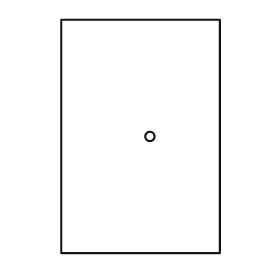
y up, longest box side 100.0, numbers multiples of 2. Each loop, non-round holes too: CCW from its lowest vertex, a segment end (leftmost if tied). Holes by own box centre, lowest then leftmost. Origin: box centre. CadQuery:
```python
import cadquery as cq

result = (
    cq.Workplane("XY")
    .moveTo(-34.0, -50.0)
    .lineTo(34.0, -50.0)
    .lineTo(34.0, 50.0)
    .lineTo(-34.0, 50.0)
    .close()
    .moveTo(4.0, 0.0)
    .circle(2.0)
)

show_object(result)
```